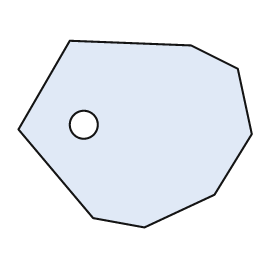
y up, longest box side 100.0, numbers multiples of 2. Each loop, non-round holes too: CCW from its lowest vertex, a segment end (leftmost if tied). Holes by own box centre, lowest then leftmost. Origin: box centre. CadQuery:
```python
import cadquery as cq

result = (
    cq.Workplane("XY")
    .moveTo(4.0, -40.0)
    .lineTo(34.0, -26.0)
    .lineTo(50.0, 0.0)
    .lineTo(44.0, 28.0)
    .lineTo(24.0, 38.0)
    .lineTo(-28.0, 40.0)
    .lineTo(-50.0, 2.0)
    .lineTo(-18.0, -36.0)
    .close()
    .moveTo(-22.0, 4.0)
    .circle(6.0)
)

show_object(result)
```